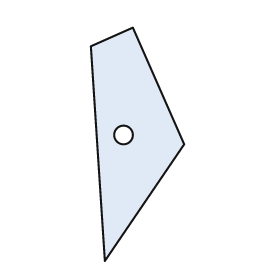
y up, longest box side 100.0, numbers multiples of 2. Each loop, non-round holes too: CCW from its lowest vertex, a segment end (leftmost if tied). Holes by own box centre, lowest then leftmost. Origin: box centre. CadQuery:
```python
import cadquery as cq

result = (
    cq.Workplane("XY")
    .moveTo(-14.0, -50.0)
    .lineTo(20.0, 0.0)
    .lineTo(-2.0, 50.0)
    .lineTo(-20.0, 42.0)
    .close()
    .moveTo(-6.0, 4.0)
    .circle(4.0)
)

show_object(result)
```